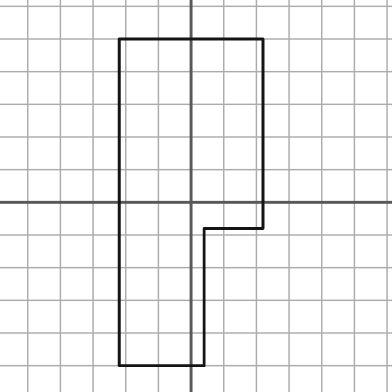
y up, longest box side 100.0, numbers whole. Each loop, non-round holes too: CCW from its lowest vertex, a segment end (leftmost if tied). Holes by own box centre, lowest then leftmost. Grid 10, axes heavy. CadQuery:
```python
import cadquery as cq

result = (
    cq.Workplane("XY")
    .moveTo(-22.0, -50.0)
    .lineTo(4.0, -50.0)
    .lineTo(4.0, -8.0)
    .lineTo(22.0, -8.0)
    .lineTo(22.0, 50.0)
    .lineTo(-22.0, 50.0)
    .close()
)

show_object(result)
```